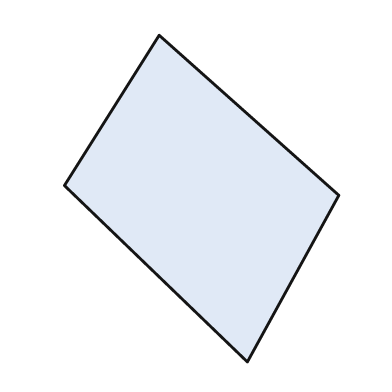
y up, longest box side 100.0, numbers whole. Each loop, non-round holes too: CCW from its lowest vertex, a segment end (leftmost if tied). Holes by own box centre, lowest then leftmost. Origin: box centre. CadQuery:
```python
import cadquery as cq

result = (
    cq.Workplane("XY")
    .moveTo(14.0, -50.0)
    .lineTo(42.0, 1.0)
    .lineTo(-13.0, 50.0)
    .lineTo(-42.0, 4.0)
    .close()
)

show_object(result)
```